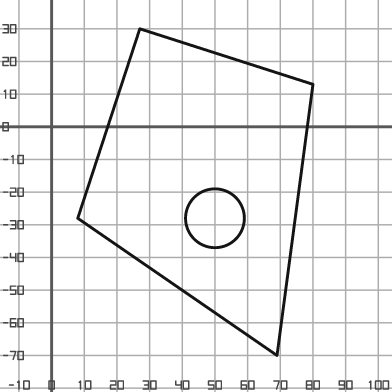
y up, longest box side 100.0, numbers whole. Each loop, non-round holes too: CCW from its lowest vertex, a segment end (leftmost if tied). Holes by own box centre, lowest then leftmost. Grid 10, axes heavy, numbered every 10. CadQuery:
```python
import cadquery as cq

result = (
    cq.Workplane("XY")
    .moveTo(69.0, -70.0)
    .lineTo(80.0, 13.0)
    .lineTo(27.0, 30.0)
    .lineTo(8.0, -28.0)
    .close()
    .moveTo(50.0, -28.0)
    .circle(9.0)
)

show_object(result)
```